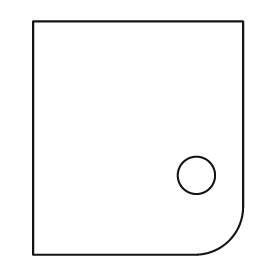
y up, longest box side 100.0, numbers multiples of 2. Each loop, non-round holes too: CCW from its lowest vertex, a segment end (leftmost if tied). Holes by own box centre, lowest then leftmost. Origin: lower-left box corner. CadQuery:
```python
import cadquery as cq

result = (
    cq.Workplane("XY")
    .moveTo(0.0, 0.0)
    .lineTo(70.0, 0.0)
    .threePointArc((84.0, 6.0), (90.0, 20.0))
    .lineTo(90.0, 100.0)
    .lineTo(0.0, 100.0)
    .close()
    .moveTo(70.0, 34.0)
    .circle(8.0)
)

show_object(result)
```